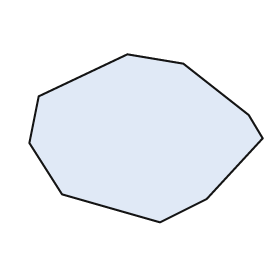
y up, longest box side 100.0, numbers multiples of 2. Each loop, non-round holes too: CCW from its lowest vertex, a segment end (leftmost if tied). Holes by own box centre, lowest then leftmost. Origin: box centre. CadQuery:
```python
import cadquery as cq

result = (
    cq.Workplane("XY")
    .moveTo(6.0, -36.0)
    .lineTo(26.0, -26.0)
    .lineTo(50.0, 0.0)
    .lineTo(44.0, 10.0)
    .lineTo(16.0, 32.0)
    .lineTo(-8.0, 36.0)
    .lineTo(-46.0, 18.0)
    .lineTo(-50.0, -2.0)
    .lineTo(-36.0, -24.0)
    .close()
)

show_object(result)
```